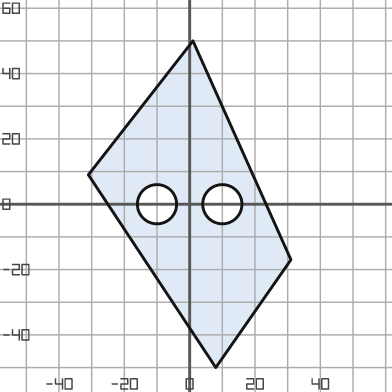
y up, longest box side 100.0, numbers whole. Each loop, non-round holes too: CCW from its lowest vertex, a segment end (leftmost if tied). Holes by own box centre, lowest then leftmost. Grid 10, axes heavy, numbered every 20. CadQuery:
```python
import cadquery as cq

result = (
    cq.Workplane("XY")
    .moveTo(8.0, -50.0)
    .lineTo(31.0, -17.0)
    .lineTo(1.0, 50.0)
    .lineTo(-31.0, 9.0)
    .close()
    .moveTo(-10.0, 0.0)
    .circle(6.0)
    .moveTo(10.0, 0.0)
    .circle(6.0)
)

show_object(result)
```